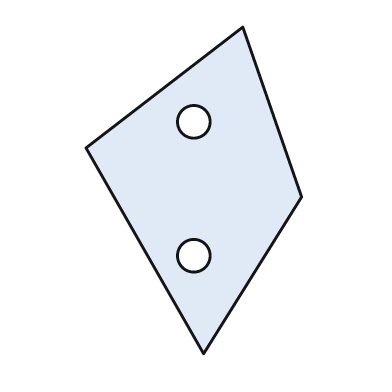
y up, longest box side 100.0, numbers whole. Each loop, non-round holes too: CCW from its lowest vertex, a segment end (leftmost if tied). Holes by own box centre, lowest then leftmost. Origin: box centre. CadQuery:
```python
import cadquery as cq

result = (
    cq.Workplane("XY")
    .moveTo(3.0, -50.0)
    .lineTo(33.0, -2.0)
    .lineTo(15.0, 50.0)
    .lineTo(-33.0, 13.0)
    .close()
    .moveTo(0.0, -20.0)
    .circle(5.0)
    .moveTo(0.0, 21.0)
    .circle(5.0)
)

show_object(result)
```